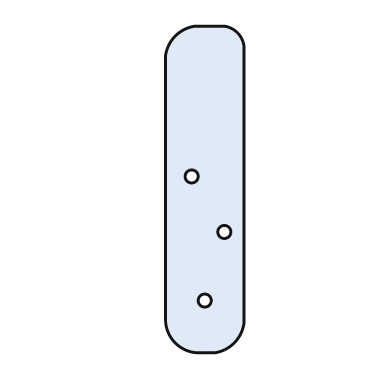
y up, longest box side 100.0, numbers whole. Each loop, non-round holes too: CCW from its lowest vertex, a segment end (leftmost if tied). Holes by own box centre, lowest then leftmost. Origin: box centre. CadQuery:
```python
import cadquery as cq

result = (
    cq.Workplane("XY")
    .moveTo(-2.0, -50.0)
    .lineTo(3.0, -50.0)
    .threePointArc((9.0, -47.0), (12.0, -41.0))
    .lineTo(12.0, 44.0)
    .threePointArc((10.0, 48.0), (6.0, 50.0))
    .lineTo(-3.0, 50.0)
    .threePointArc((-9.0, 47.0), (-12.0, 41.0))
    .lineTo(-12.0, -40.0)
    .threePointArc((-9.0, -47.0), (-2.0, -50.0))
    .close()
    .moveTo(0.0, -34.0)
    .circle(2.0)
    .moveTo(6.0, -13.0)
    .circle(2.0)
    .moveTo(-4.0, 4.0)
    .circle(2.0)
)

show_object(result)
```